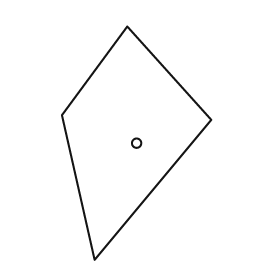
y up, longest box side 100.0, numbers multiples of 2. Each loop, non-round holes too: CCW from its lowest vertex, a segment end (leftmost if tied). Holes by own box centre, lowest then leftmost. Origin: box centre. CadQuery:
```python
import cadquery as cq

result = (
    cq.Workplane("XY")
    .moveTo(-18.0, -50.0)
    .lineTo(32.0, 10.0)
    .lineTo(-4.0, 50.0)
    .lineTo(-32.0, 12.0)
    .close()
    .moveTo(0.0, 0.0)
    .circle(2.0)
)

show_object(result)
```